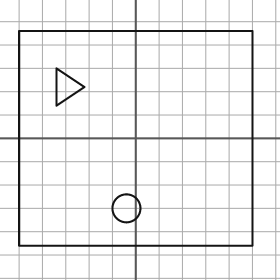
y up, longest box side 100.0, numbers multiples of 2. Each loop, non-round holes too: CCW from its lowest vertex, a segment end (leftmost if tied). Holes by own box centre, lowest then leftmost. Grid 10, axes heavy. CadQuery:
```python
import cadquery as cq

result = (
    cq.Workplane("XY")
    .moveTo(-50.0, -46.0)
    .lineTo(50.0, -46.0)
    .lineTo(50.0, 46.0)
    .lineTo(-50.0, 46.0)
    .close()
    .moveTo(-4.0, -30.0)
    .circle(6.0)
    .moveTo(-34.0, 14.0)
    .lineTo(-22.0, 22.0)
    .lineTo(-34.0, 30.0)
    .close()
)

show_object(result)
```